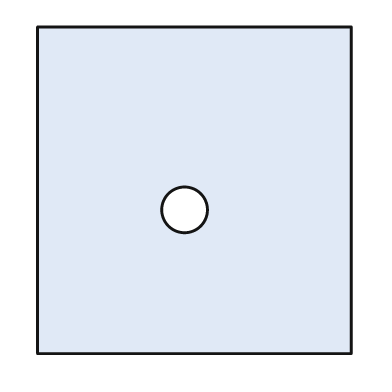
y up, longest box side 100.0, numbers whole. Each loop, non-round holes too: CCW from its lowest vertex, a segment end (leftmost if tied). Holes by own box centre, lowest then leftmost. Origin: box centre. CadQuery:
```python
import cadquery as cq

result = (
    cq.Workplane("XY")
    .moveTo(-48.0, -50.0)
    .lineTo(48.0, -50.0)
    .lineTo(48.0, 50.0)
    .lineTo(-48.0, 50.0)
    .close()
    .moveTo(-3.0, -6.0)
    .circle(7.0)
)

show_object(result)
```